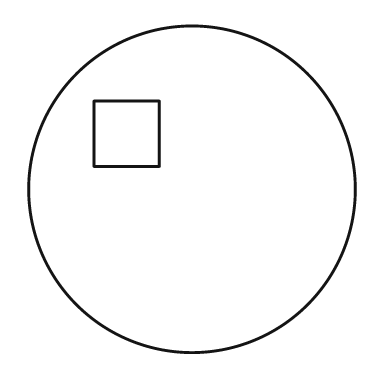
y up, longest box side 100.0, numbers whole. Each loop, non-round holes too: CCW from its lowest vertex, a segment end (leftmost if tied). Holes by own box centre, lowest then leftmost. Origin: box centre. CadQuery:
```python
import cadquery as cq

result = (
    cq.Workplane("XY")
    .moveTo(0.0, 0.0)
    .circle(50.0)
    .moveTo(-30.0, 7.0)
    .lineTo(-10.0, 7.0)
    .lineTo(-10.0, 27.0)
    .lineTo(-30.0, 27.0)
    .close()
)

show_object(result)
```